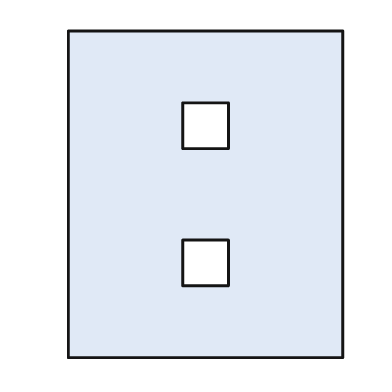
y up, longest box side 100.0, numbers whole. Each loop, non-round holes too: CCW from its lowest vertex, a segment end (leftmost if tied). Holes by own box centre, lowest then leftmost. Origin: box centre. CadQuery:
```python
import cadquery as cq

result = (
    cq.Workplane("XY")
    .moveTo(-42.0, -50.0)
    .lineTo(42.0, -50.0)
    .lineTo(42.0, 50.0)
    .lineTo(-42.0, 50.0)
    .close()
    .moveTo(-7.0, -28.0)
    .lineTo(7.0, -28.0)
    .lineTo(7.0, -14.0)
    .lineTo(-7.0, -14.0)
    .close()
    .moveTo(-7.0, 14.0)
    .lineTo(7.0, 14.0)
    .lineTo(7.0, 28.0)
    .lineTo(-7.0, 28.0)
    .close()
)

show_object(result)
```